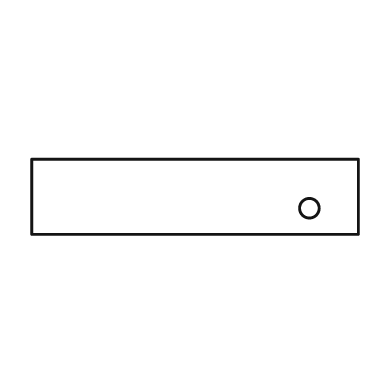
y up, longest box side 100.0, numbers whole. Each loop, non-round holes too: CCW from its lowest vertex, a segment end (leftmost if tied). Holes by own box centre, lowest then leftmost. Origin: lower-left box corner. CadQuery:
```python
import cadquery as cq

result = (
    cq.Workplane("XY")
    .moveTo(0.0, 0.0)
    .lineTo(100.0, 0.0)
    .lineTo(100.0, 23.0)
    .lineTo(0.0, 23.0)
    .close()
    .moveTo(85.0, 8.0)
    .circle(3.0)
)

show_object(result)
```